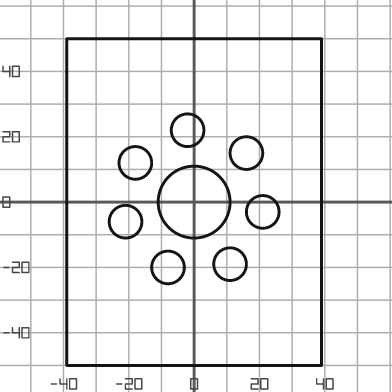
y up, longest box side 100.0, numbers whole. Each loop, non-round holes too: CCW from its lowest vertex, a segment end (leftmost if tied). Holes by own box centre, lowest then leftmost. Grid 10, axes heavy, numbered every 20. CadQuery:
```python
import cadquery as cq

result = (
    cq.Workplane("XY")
    .moveTo(-39.0, -50.0)
    .lineTo(39.0, -50.0)
    .lineTo(39.0, 50.0)
    .lineTo(-39.0, 50.0)
    .close()
    .moveTo(-8.0, -20.0)
    .circle(5.0)
    .moveTo(11.0, -19.0)
    .circle(5.0)
    .moveTo(-21.0, -6.0)
    .circle(5.0)
    .moveTo(21.0, -3.0)
    .circle(5.0)
    .moveTo(0.0, 0.0)
    .circle(11.0)
    .moveTo(-18.0, 12.0)
    .circle(5.0)
    .moveTo(16.0, 15.0)
    .circle(5.0)
    .moveTo(-2.0, 22.0)
    .circle(5.0)
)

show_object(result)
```